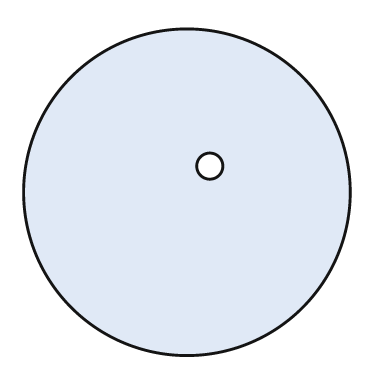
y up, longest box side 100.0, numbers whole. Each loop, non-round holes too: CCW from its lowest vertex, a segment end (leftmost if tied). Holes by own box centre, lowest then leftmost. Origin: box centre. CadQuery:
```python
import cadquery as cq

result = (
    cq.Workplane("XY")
    .moveTo(0.0, 0.0)
    .circle(50.0)
    .moveTo(7.0, 8.0)
    .circle(4.0)
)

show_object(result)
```